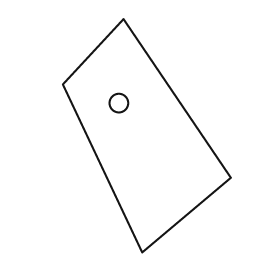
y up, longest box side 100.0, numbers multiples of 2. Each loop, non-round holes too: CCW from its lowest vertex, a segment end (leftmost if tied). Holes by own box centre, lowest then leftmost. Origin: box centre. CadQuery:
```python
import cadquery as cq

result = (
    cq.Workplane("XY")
    .moveTo(-2.0, -50.0)
    .lineTo(36.0, -18.0)
    .lineTo(-10.0, 50.0)
    .lineTo(-36.0, 22.0)
    .close()
    .moveTo(-12.0, 14.0)
    .circle(4.0)
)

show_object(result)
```